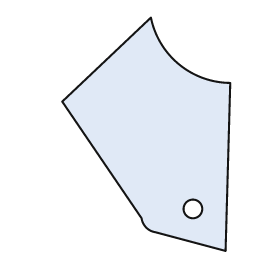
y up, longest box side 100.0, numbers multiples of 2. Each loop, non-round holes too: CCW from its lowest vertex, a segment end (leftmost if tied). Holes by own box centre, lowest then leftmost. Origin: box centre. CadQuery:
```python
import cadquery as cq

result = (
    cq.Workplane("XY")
    .moveTo(34.0, -50.0)
    .lineTo(36.0, 22.0)
    .threePointArc((14.0, 30.0), (2.0, 50.0))
    .lineTo(-36.0, 14.0)
    .lineTo(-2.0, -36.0)
    .threePointArc((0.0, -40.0), (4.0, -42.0))
    .close()
    .moveTo(20.0, -32.0)
    .circle(4.0)
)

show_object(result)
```